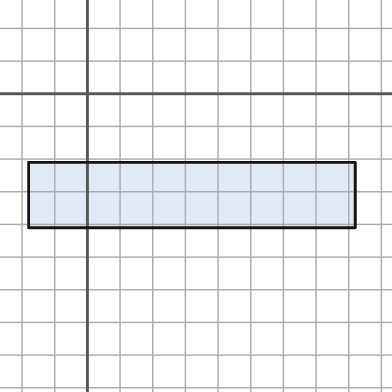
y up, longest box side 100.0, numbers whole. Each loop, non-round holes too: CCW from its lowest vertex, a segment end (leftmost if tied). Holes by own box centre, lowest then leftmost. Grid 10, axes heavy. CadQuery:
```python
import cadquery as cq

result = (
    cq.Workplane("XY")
    .moveTo(-18.0, -41.0)
    .lineTo(82.0, -41.0)
    .lineTo(82.0, -21.0)
    .lineTo(-18.0, -21.0)
    .close()
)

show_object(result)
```